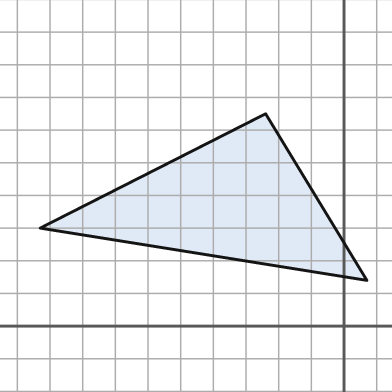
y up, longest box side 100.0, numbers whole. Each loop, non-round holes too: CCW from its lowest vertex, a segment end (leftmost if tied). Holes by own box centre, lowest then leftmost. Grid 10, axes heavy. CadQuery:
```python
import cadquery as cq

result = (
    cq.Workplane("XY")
    .moveTo(7.0, 14.0)
    .lineTo(-24.0, 65.0)
    .lineTo(-93.0, 30.0)
    .close()
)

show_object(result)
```